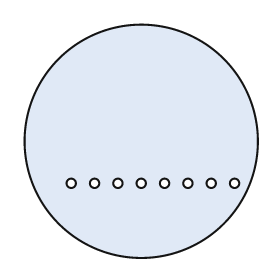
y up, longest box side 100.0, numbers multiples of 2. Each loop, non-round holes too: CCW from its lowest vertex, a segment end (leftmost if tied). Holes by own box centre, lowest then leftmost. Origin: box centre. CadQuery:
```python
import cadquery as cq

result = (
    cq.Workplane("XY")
    .moveTo(0.0, 0.0)
    .circle(50.0)
    .moveTo(-30.0, -18.0)
    .circle(2.0)
    .moveTo(-20.0, -18.0)
    .circle(2.0)
    .moveTo(-10.0, -18.0)
    .circle(2.0)
    .moveTo(0.0, -18.0)
    .circle(2.0)
    .moveTo(10.0, -18.0)
    .circle(2.0)
    .moveTo(20.0, -18.0)
    .circle(2.0)
    .moveTo(30.0, -18.0)
    .circle(2.0)
    .moveTo(40.0, -18.0)
    .circle(2.0)
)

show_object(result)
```